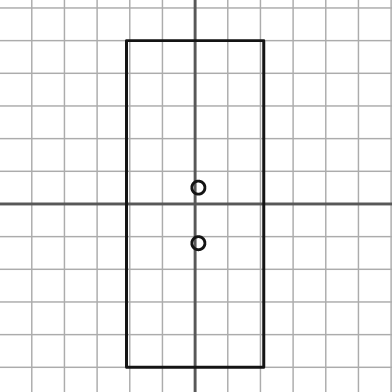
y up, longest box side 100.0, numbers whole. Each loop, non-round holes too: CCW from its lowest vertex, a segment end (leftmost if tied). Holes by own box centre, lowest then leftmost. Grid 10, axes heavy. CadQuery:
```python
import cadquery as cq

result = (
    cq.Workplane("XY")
    .moveTo(-21.0, -50.0)
    .lineTo(21.0, -50.0)
    .lineTo(21.0, 50.0)
    .lineTo(-21.0, 50.0)
    .close()
    .moveTo(1.0, -12.0)
    .circle(2.0)
    .moveTo(1.0, 5.0)
    .circle(2.0)
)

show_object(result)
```